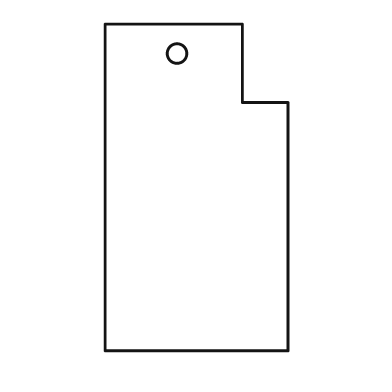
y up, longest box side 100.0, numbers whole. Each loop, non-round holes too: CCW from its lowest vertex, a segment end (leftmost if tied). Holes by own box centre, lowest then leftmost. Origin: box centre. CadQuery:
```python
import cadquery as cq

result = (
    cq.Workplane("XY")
    .moveTo(-28.0, -50.0)
    .lineTo(28.0, -50.0)
    .lineTo(28.0, 26.0)
    .lineTo(14.0, 26.0)
    .lineTo(14.0, 50.0)
    .lineTo(-28.0, 50.0)
    .close()
    .moveTo(-6.0, 41.0)
    .circle(3.0)
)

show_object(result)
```